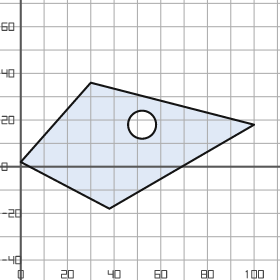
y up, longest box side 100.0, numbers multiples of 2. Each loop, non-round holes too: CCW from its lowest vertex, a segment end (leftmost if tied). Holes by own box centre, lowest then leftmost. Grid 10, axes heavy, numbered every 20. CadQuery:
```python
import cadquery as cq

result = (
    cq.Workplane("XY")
    .moveTo(38.0, -18.0)
    .lineTo(100.0, 18.0)
    .lineTo(30.0, 36.0)
    .lineTo(0.0, 2.0)
    .close()
    .moveTo(52.0, 18.0)
    .circle(6.0)
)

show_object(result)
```